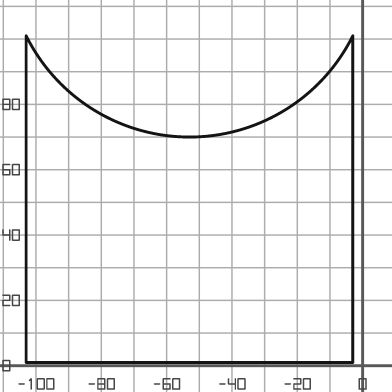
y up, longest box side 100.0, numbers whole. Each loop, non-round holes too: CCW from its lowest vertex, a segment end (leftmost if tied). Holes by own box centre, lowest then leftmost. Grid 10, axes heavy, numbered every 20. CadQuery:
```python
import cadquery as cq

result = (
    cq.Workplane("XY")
    .moveTo(-103.0, 1.0)
    .lineTo(-3.0, 1.0)
    .lineTo(-3.0, 101.0)
    .threePointArc((-53.0, 70.0), (-103.0, 101.0))
    .close()
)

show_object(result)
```